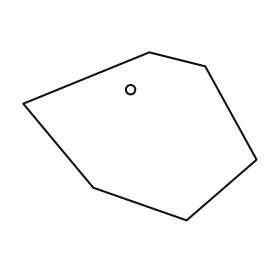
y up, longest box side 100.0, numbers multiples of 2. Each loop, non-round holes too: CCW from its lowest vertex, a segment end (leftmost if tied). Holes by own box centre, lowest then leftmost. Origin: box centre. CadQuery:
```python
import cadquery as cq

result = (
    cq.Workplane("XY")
    .moveTo(20.0, -36.0)
    .lineTo(50.0, -10.0)
    .lineTo(28.0, 30.0)
    .lineTo(4.0, 36.0)
    .lineTo(-50.0, 14.0)
    .lineTo(-20.0, -22.0)
    .close()
    .moveTo(-4.0, 20.0)
    .circle(2.0)
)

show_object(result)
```